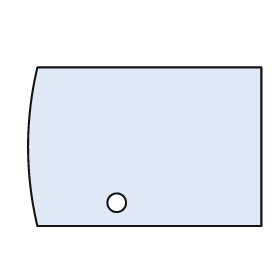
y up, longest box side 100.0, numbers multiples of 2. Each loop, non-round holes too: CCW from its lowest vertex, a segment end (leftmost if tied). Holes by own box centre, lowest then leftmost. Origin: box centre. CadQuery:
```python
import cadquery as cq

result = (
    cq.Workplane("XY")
    .moveTo(-46.0, -34.0)
    .lineTo(50.0, -34.0)
    .lineTo(50.0, 34.0)
    .lineTo(-46.0, 34.0)
    .threePointArc((-50.0, 0.0), (-46.0, -34.0))
    .close()
    .moveTo(-12.0, -24.0)
    .circle(4.0)
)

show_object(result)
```